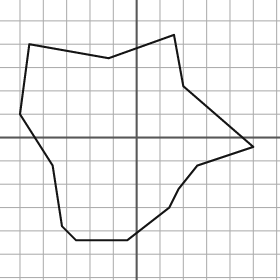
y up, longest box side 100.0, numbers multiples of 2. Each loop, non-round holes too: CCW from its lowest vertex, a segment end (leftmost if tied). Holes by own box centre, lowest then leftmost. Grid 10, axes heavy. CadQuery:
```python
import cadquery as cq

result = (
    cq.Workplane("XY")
    .moveTo(-26.0, -44.0)
    .lineTo(-4.0, -44.0)
    .lineTo(14.0, -30.0)
    .lineTo(18.0, -22.0)
    .lineTo(26.0, -12.0)
    .lineTo(50.0, -4.0)
    .lineTo(20.0, 22.0)
    .lineTo(16.0, 44.0)
    .lineTo(-12.0, 34.0)
    .lineTo(-46.0, 40.0)
    .lineTo(-50.0, 10.0)
    .lineTo(-36.0, -12.0)
    .lineTo(-32.0, -38.0)
    .close()
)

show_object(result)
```